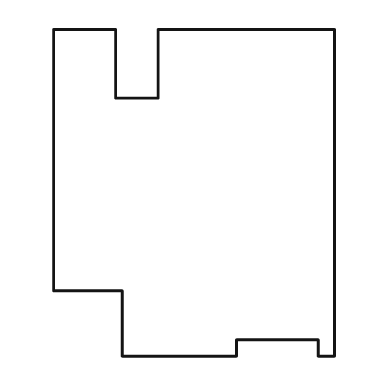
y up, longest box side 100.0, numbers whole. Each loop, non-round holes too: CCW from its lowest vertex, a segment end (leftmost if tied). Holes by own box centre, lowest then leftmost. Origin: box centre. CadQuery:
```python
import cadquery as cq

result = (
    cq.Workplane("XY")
    .moveTo(-22.0, -50.0)
    .lineTo(13.0, -50.0)
    .lineTo(13.0, -45.0)
    .lineTo(38.0, -45.0)
    .lineTo(38.0, -50.0)
    .lineTo(43.0, -50.0)
    .lineTo(43.0, 50.0)
    .lineTo(-11.0, 50.0)
    .lineTo(-11.0, 29.0)
    .lineTo(-24.0, 29.0)
    .lineTo(-24.0, 50.0)
    .lineTo(-43.0, 50.0)
    .lineTo(-43.0, -30.0)
    .lineTo(-22.0, -30.0)
    .close()
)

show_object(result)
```